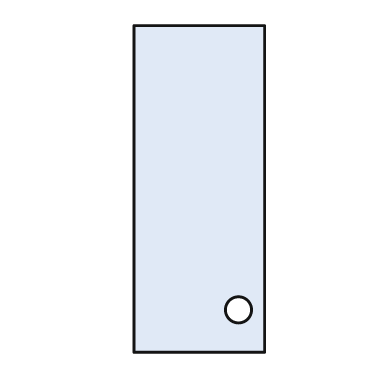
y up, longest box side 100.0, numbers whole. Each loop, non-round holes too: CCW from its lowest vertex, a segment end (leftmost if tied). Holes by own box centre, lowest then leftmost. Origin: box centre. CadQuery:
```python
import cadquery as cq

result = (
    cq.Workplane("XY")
    .moveTo(-20.0, -50.0)
    .lineTo(20.0, -50.0)
    .lineTo(20.0, 50.0)
    .lineTo(-20.0, 50.0)
    .close()
    .moveTo(12.0, -37.0)
    .circle(4.0)
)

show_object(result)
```